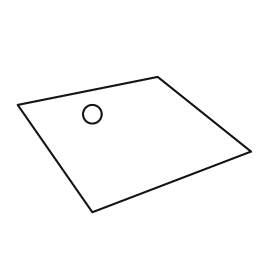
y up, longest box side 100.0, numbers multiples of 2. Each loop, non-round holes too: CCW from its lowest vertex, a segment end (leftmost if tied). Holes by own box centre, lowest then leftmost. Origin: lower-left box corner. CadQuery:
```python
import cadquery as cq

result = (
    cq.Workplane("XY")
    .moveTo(32.0, 0.0)
    .lineTo(100.0, 26.0)
    .lineTo(60.0, 58.0)
    .lineTo(0.0, 46.0)
    .close()
    .moveTo(32.0, 42.0)
    .circle(4.0)
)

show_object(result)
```